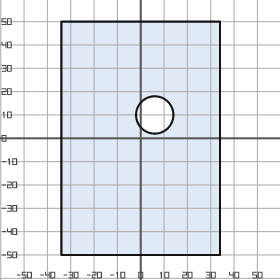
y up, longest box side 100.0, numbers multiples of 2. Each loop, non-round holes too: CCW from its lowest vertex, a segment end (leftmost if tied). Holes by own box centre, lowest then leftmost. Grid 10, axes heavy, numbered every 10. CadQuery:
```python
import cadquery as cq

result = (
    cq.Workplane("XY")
    .moveTo(-34.0, -50.0)
    .lineTo(34.0, -50.0)
    .lineTo(34.0, 50.0)
    .lineTo(-34.0, 50.0)
    .close()
    .moveTo(6.0, 10.0)
    .circle(8.0)
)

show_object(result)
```